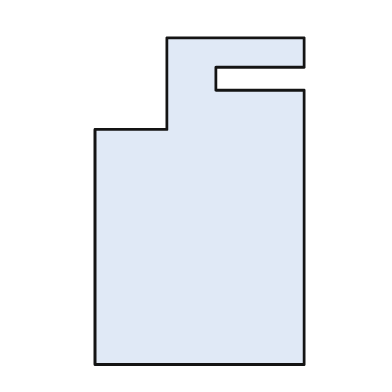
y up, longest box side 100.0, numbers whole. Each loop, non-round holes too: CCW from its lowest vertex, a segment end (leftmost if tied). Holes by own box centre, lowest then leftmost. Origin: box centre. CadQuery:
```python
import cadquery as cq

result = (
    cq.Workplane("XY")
    .moveTo(-32.0, -50.0)
    .lineTo(32.0, -50.0)
    .lineTo(32.0, 34.0)
    .lineTo(5.0, 34.0)
    .lineTo(5.0, 41.0)
    .lineTo(32.0, 41.0)
    .lineTo(32.0, 50.0)
    .lineTo(-10.0, 50.0)
    .lineTo(-10.0, 22.0)
    .lineTo(-32.0, 22.0)
    .close()
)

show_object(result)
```